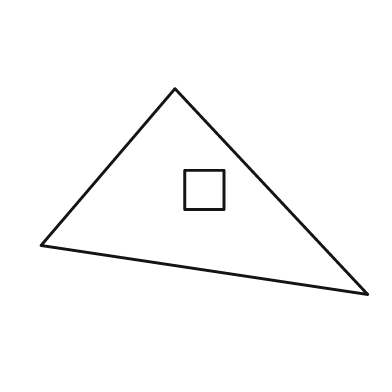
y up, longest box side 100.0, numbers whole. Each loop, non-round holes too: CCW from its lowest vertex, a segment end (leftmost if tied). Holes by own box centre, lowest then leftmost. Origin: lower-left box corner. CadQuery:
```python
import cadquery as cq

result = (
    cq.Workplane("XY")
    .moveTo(100.0, 0.0)
    .lineTo(41.0, 63.0)
    .lineTo(0.0, 15.0)
    .close()
    .moveTo(44.0, 26.0)
    .lineTo(56.0, 26.0)
    .lineTo(56.0, 38.0)
    .lineTo(44.0, 38.0)
    .close()
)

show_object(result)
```